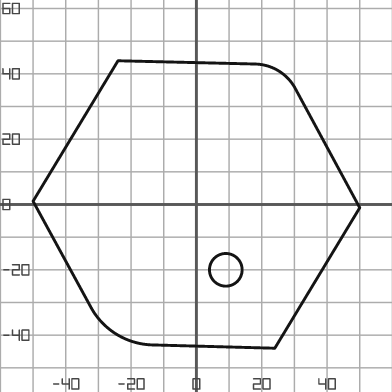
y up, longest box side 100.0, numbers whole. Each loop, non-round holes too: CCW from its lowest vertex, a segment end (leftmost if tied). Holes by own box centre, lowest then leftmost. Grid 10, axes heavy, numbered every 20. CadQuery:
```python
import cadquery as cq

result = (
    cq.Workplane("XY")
    .moveTo(24.0, -44.0)
    .lineTo(50.0, -1.0)
    .lineTo(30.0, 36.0)
    .threePointArc((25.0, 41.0), (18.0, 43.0))
    .lineTo(-24.0, 44.0)
    .lineTo(-50.0, 1.0)
    .lineTo(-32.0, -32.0)
    .threePointArc((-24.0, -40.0), (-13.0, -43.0))
    .close()
    .moveTo(9.0, -20.0)
    .circle(5.0)
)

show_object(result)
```